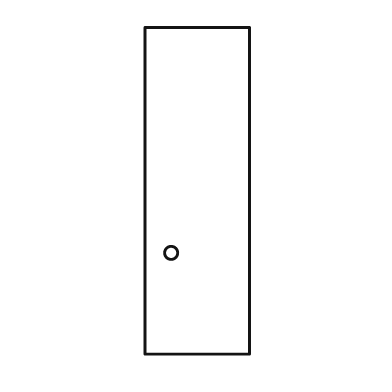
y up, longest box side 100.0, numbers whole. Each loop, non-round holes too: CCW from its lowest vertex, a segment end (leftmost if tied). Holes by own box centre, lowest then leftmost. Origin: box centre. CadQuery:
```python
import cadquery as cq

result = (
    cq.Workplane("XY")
    .moveTo(-16.0, -50.0)
    .lineTo(16.0, -50.0)
    .lineTo(16.0, 50.0)
    .lineTo(-16.0, 50.0)
    .close()
    .moveTo(-8.0, -19.0)
    .circle(2.0)
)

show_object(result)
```